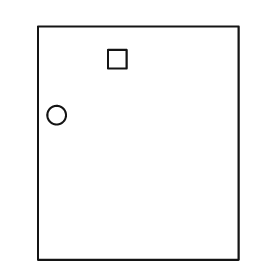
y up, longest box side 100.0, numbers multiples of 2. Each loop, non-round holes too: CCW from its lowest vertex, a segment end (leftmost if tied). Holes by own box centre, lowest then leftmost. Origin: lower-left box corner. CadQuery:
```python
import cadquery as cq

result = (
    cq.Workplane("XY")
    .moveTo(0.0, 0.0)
    .lineTo(86.0, 0.0)
    .lineTo(86.0, 100.0)
    .lineTo(0.0, 100.0)
    .close()
    .moveTo(8.0, 62.0)
    .circle(4.0)
    .moveTo(30.0, 82.0)
    .lineTo(38.0, 82.0)
    .lineTo(38.0, 90.0)
    .lineTo(30.0, 90.0)
    .close()
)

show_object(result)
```